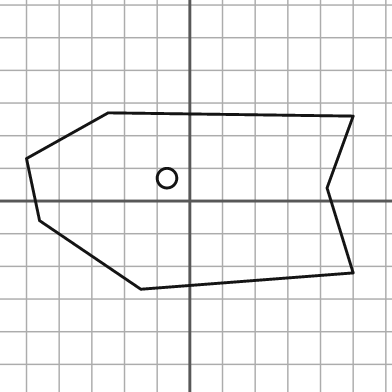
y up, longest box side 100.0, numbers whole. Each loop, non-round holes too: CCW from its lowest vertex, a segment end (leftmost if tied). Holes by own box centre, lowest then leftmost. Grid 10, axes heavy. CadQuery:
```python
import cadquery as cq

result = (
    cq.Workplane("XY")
    .moveTo(-15.0, -27.0)
    .lineTo(50.0, -22.0)
    .lineTo(42.0, 4.0)
    .lineTo(50.0, 26.0)
    .lineTo(-25.0, 27.0)
    .lineTo(-50.0, 13.0)
    .lineTo(-46.0, -6.0)
    .close()
    .moveTo(-7.0, 7.0)
    .circle(3.0)
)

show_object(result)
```